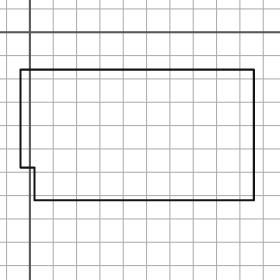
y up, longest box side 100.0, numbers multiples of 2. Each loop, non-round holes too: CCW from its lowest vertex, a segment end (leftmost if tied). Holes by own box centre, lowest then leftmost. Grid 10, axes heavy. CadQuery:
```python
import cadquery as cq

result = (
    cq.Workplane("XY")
    .moveTo(2.0, -72.0)
    .lineTo(96.0, -72.0)
    .lineTo(96.0, -16.0)
    .lineTo(-4.0, -16.0)
    .lineTo(-4.0, -58.0)
    .lineTo(2.0, -58.0)
    .close()
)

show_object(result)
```